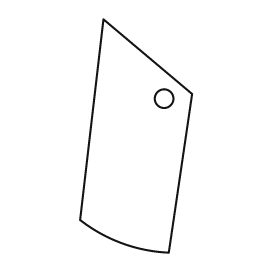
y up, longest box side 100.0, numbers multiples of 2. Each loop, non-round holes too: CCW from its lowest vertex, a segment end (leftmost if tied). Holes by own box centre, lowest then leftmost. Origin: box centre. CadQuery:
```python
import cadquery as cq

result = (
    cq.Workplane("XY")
    .moveTo(14.0, -50.0)
    .lineTo(24.0, 18.0)
    .lineTo(-14.0, 50.0)
    .lineTo(-24.0, -36.0)
    .threePointArc((-6.0, -46.0), (14.0, -50.0))
    .close()
    .moveTo(12.0, 16.0)
    .circle(4.0)
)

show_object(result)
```